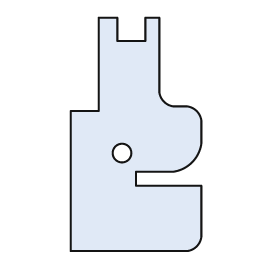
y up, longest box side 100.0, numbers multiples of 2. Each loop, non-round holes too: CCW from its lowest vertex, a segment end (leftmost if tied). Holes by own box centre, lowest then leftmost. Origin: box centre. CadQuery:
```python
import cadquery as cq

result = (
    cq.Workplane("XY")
    .moveTo(-28.0, -50.0)
    .lineTo(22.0, -50.0)
    .threePointArc((26.0, -48.0), (28.0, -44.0))
    .lineTo(28.0, -22.0)
    .lineTo(0.0, -22.0)
    .lineTo(0.0, -16.0)
    .lineTo(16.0, -16.0)
    .threePointArc((24.0, -12.0), (28.0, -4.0))
    .lineTo(28.0, 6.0)
    .threePointArc((26.0, 10.0), (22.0, 12.0))
    .lineTo(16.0, 12.0)
    .threePointArc((12.0, 14.0), (10.0, 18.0))
    .lineTo(10.0, 50.0)
    .lineTo(4.0, 50.0)
    .lineTo(4.0, 40.0)
    .lineTo(-8.0, 40.0)
    .lineTo(-8.0, 50.0)
    .lineTo(-16.0, 50.0)
    .lineTo(-16.0, 10.0)
    .lineTo(-28.0, 10.0)
    .close()
    .moveTo(-6.0, -8.0)
    .circle(4.0)
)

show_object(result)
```